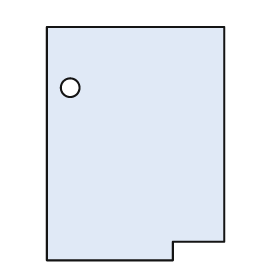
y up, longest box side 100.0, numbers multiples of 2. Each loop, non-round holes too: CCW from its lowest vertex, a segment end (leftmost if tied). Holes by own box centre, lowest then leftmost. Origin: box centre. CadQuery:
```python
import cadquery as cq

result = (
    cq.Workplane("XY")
    .moveTo(-38.0, -50.0)
    .lineTo(16.0, -50.0)
    .lineTo(16.0, -42.0)
    .lineTo(38.0, -42.0)
    .lineTo(38.0, 50.0)
    .lineTo(-38.0, 50.0)
    .close()
    .moveTo(-28.0, 24.0)
    .circle(4.0)
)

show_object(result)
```